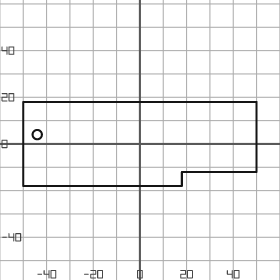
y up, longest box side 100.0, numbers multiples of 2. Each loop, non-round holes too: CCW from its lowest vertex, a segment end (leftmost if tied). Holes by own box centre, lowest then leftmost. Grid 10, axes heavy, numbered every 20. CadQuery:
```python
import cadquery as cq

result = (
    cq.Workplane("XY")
    .moveTo(-50.0, -18.0)
    .lineTo(18.0, -18.0)
    .lineTo(18.0, -12.0)
    .lineTo(50.0, -12.0)
    .lineTo(50.0, 18.0)
    .lineTo(-50.0, 18.0)
    .close()
    .moveTo(-44.0, 4.0)
    .circle(2.0)
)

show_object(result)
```